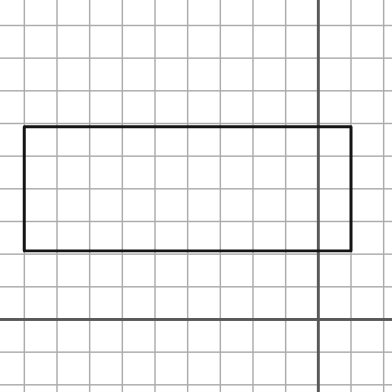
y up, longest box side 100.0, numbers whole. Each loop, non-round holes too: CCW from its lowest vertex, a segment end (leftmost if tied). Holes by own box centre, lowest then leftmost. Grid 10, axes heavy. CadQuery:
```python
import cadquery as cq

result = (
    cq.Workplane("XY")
    .moveTo(-90.0, 21.0)
    .lineTo(10.0, 21.0)
    .lineTo(10.0, 59.0)
    .lineTo(-90.0, 59.0)
    .close()
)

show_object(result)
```